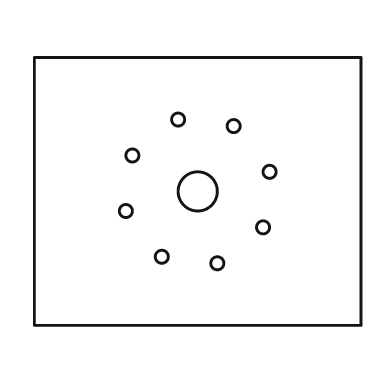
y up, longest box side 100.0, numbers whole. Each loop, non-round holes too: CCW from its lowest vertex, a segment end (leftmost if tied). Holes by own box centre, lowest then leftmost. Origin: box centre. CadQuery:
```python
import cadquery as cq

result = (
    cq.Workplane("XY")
    .moveTo(-50.0, -41.0)
    .lineTo(50.0, -41.0)
    .lineTo(50.0, 41.0)
    .lineTo(-50.0, 41.0)
    .close()
    .moveTo(6.0, -22.0)
    .circle(2.0)
    .moveTo(-11.0, -20.0)
    .circle(2.0)
    .moveTo(20.0, -11.0)
    .circle(2.0)
    .moveTo(-22.0, -6.0)
    .circle(2.0)
    .moveTo(0.0, 0.0)
    .circle(6.0)
    .moveTo(22.0, 6.0)
    .circle(2.0)
    .moveTo(-20.0, 11.0)
    .circle(2.0)
    .moveTo(11.0, 20.0)
    .circle(2.0)
    .moveTo(-6.0, 22.0)
    .circle(2.0)
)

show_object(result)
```